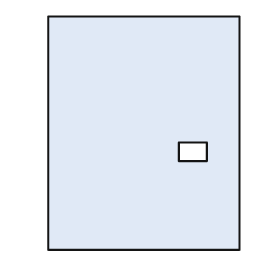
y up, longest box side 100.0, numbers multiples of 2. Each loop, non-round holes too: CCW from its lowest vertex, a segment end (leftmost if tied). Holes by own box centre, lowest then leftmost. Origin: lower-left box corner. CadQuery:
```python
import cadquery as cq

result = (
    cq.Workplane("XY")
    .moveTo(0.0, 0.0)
    .lineTo(82.0, 0.0)
    .lineTo(82.0, 100.0)
    .lineTo(0.0, 100.0)
    .close()
    .moveTo(56.0, 38.0)
    .lineTo(68.0, 38.0)
    .lineTo(68.0, 46.0)
    .lineTo(56.0, 46.0)
    .close()
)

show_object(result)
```